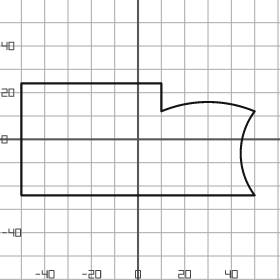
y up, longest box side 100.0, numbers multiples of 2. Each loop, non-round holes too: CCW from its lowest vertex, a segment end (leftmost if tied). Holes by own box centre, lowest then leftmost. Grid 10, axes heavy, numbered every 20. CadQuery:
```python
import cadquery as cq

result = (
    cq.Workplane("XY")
    .moveTo(-50.0, -24.0)
    .lineTo(50.0, -24.0)
    .threePointArc((44.0, -6.0), (50.0, 12.0))
    .threePointArc((30.0, 16.0), (10.0, 12.0))
    .lineTo(10.0, 24.0)
    .lineTo(-50.0, 24.0)
    .close()
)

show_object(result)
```